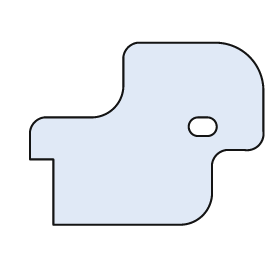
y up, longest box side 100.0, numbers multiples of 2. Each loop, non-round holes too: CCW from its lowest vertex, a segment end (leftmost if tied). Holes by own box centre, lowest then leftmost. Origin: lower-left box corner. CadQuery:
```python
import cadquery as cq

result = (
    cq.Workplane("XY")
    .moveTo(10.0, 0.0)
    .lineTo(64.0, 0.0)
    .threePointArc((74.0, 4.0), (78.0, 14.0))
    .lineTo(78.0, 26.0)
    .threePointArc((80.0, 30.0), (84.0, 32.0))
    .lineTo(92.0, 32.0)
    .threePointArc((98.0, 34.0), (100.0, 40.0))
    .lineTo(100.0, 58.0)
    .threePointArc((94.0, 72.0), (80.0, 78.0))
    .lineTo(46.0, 78.0)
    .threePointArc((42.0, 76.0), (40.0, 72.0))
    .lineTo(40.0, 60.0)
    .threePointArc((36.0, 50.0), (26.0, 46.0))
    .lineTo(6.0, 46.0)
    .threePointArc((2.0, 44.0), (0.0, 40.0))
    .lineTo(0.0, 28.0)
    .lineTo(10.0, 28.0)
    .close()
    .moveTo(72.0, 38.0)
    .lineTo(76.0, 38.0)
    .threePointArc((80.0, 42.0), (76.0, 46.0))
    .lineTo(72.0, 46.0)
    .threePointArc((68.0, 42.0), (72.0, 38.0))
    .close()
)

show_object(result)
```